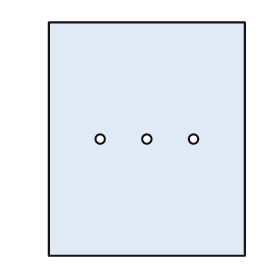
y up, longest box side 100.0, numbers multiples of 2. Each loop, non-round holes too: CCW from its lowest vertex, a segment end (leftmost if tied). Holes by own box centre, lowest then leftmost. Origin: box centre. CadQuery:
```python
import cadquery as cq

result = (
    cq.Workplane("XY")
    .moveTo(-42.0, -50.0)
    .lineTo(42.0, -50.0)
    .lineTo(42.0, 50.0)
    .lineTo(-42.0, 50.0)
    .close()
    .moveTo(-20.0, 0.0)
    .circle(2.0)
    .moveTo(0.0, 0.0)
    .circle(2.0)
    .moveTo(20.0, 0.0)
    .circle(2.0)
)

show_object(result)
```